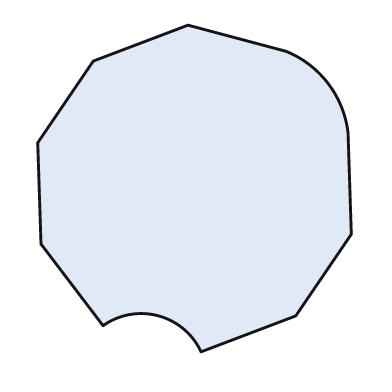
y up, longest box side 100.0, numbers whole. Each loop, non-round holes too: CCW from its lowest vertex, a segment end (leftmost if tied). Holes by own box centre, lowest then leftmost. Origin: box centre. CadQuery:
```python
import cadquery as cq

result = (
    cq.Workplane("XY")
    .moveTo(2.0, -50.0)
    .lineTo(31.0, -39.0)
    .lineTo(48.0, -14.0)
    .lineTo(47.0, 17.0)
    .threePointArc((41.0, 32.0), (28.0, 42.0))
    .lineTo(-2.0, 50.0)
    .lineTo(-31.0, 39.0)
    .lineTo(-48.0, 14.0)
    .lineTo(-47.0, -17.0)
    .lineTo(-28.0, -42.0)
    .threePointArc((-11.0, -39.0), (2.0, -50.0))
    .close()
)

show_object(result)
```